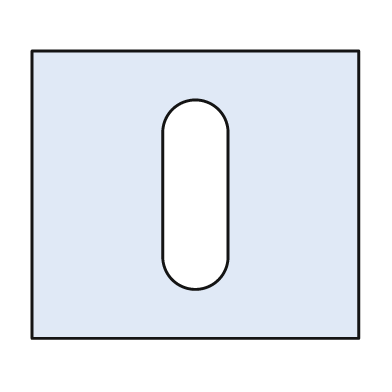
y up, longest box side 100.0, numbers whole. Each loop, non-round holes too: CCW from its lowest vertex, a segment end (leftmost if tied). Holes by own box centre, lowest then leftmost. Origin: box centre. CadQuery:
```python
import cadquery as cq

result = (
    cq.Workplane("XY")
    .moveTo(-50.0, -44.0)
    .lineTo(50.0, -44.0)
    .lineTo(50.0, 44.0)
    .lineTo(-50.0, 44.0)
    .close()
    .moveTo(-10.0, -19.0)
    .threePointArc((0.0, -29.0), (10.0, -19.0))
    .lineTo(10.0, 19.0)
    .threePointArc((0.0, 29.0), (-10.0, 19.0))
    .close()
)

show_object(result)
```